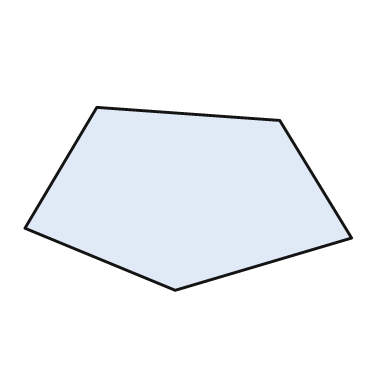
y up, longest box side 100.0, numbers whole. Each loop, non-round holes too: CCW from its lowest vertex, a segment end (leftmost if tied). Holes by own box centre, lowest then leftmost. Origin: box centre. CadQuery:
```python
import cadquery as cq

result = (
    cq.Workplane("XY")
    .moveTo(-4.0, -28.0)
    .lineTo(50.0, -12.0)
    .lineTo(28.0, 24.0)
    .lineTo(-28.0, 28.0)
    .lineTo(-50.0, -9.0)
    .close()
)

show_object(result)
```